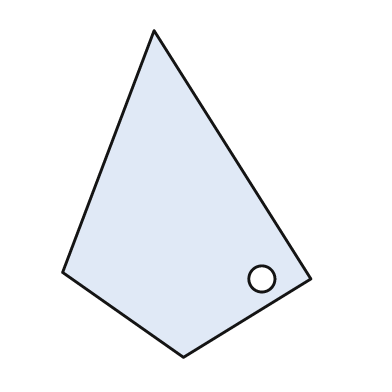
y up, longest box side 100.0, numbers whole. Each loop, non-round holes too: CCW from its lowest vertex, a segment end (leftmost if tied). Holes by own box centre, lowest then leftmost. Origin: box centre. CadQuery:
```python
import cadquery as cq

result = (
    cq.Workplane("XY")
    .moveTo(-1.0, -50.0)
    .lineTo(38.0, -26.0)
    .lineTo(-10.0, 50.0)
    .lineTo(-38.0, -24.0)
    .close()
    .moveTo(23.0, -26.0)
    .circle(4.0)
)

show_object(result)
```